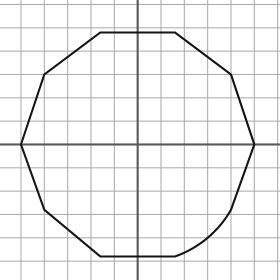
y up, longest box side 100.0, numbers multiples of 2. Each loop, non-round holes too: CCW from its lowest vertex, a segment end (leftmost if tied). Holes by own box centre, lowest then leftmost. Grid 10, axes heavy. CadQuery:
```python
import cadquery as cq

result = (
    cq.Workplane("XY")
    .moveTo(-16.0, -48.0)
    .lineTo(16.0, -48.0)
    .threePointArc((30.0, -40.0), (40.0, -28.0))
    .lineTo(50.0, 0.0)
    .lineTo(40.0, 30.0)
    .lineTo(16.0, 48.0)
    .lineTo(-16.0, 48.0)
    .lineTo(-40.0, 30.0)
    .lineTo(-50.0, 0.0)
    .lineTo(-40.0, -28.0)
    .close()
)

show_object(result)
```